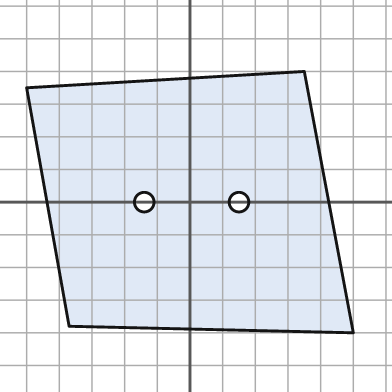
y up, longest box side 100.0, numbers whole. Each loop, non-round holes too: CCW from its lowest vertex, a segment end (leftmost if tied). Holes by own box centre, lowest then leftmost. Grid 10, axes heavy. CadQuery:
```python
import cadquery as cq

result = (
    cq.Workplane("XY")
    .moveTo(50.0, -40.0)
    .lineTo(35.0, 40.0)
    .lineTo(-50.0, 35.0)
    .lineTo(-37.0, -38.0)
    .close()
    .moveTo(-14.0, 0.0)
    .circle(3.0)
    .moveTo(15.0, 0.0)
    .circle(3.0)
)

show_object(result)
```